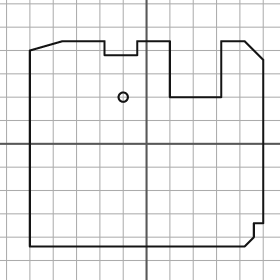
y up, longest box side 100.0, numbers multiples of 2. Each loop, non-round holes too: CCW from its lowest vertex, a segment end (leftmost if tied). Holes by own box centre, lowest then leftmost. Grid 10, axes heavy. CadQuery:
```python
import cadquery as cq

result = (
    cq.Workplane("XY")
    .moveTo(-50.0, -44.0)
    .lineTo(42.0, -44.0)
    .lineTo(46.0, -40.0)
    .lineTo(46.0, -34.0)
    .lineTo(50.0, -34.0)
    .lineTo(50.0, 36.0)
    .lineTo(42.0, 44.0)
    .lineTo(32.0, 44.0)
    .lineTo(32.0, 20.0)
    .lineTo(10.0, 20.0)
    .lineTo(10.0, 44.0)
    .lineTo(-4.0, 44.0)
    .lineTo(-4.0, 38.0)
    .lineTo(-18.0, 38.0)
    .lineTo(-18.0, 44.0)
    .lineTo(-36.0, 44.0)
    .lineTo(-50.0, 40.0)
    .close()
    .moveTo(-10.0, 20.0)
    .circle(2.0)
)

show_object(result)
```